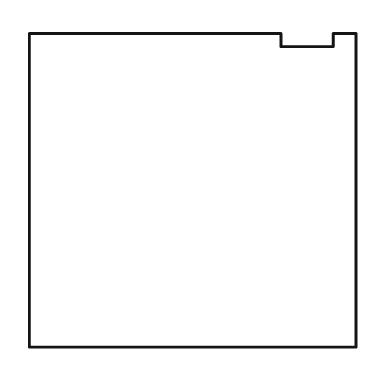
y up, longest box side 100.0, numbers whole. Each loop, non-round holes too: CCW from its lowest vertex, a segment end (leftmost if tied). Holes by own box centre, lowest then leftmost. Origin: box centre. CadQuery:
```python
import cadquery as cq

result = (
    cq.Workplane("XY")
    .moveTo(-50.0, -48.0)
    .lineTo(50.0, -48.0)
    .lineTo(50.0, 48.0)
    .lineTo(43.0, 48.0)
    .lineTo(43.0, 44.0)
    .lineTo(27.0, 44.0)
    .lineTo(27.0, 48.0)
    .lineTo(-50.0, 48.0)
    .close()
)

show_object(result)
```